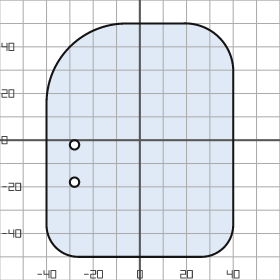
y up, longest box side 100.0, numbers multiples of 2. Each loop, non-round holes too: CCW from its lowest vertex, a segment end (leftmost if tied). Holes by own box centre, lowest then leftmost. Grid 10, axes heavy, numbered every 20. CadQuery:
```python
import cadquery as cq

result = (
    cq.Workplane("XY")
    .moveTo(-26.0, -50.0)
    .lineTo(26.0, -50.0)
    .threePointArc((36.0, -46.0), (40.0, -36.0))
    .lineTo(40.0, 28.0)
    .threePointArc((34.0, 44.0), (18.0, 50.0))
    .lineTo(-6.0, 50.0)
    .threePointArc((-30.0, 40.0), (-40.0, 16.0))
    .lineTo(-40.0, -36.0)
    .threePointArc((-36.0, -46.0), (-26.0, -50.0))
    .close()
    .moveTo(-28.0, -18.0)
    .circle(2.0)
    .moveTo(-28.0, -2.0)
    .circle(2.0)
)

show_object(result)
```